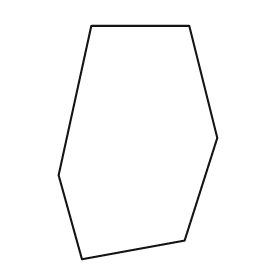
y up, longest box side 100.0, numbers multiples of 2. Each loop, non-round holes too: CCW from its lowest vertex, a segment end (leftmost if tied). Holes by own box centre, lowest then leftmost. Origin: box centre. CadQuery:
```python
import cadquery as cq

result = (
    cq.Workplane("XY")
    .moveTo(-24.0, -50.0)
    .lineTo(20.0, -42.0)
    .lineTo(34.0, 2.0)
    .lineTo(22.0, 50.0)
    .lineTo(-20.0, 50.0)
    .lineTo(-34.0, -14.0)
    .close()
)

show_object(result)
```